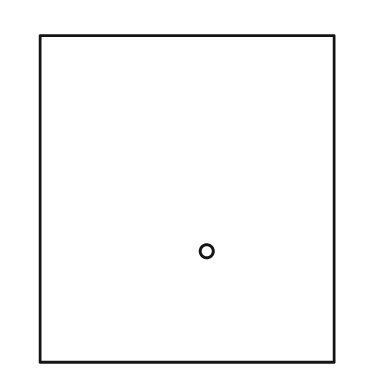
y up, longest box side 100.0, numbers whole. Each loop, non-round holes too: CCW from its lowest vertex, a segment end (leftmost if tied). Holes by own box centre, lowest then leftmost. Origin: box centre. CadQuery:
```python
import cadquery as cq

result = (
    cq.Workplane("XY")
    .moveTo(-45.0, -50.0)
    .lineTo(45.0, -50.0)
    .lineTo(45.0, 50.0)
    .lineTo(-45.0, 50.0)
    .close()
    .moveTo(6.0, -16.0)
    .circle(2.0)
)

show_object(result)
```